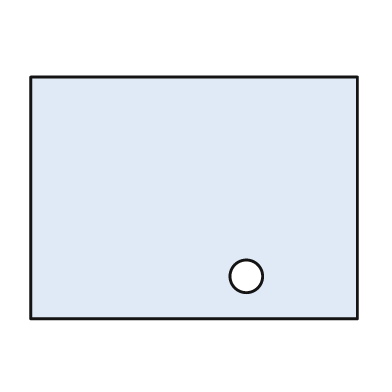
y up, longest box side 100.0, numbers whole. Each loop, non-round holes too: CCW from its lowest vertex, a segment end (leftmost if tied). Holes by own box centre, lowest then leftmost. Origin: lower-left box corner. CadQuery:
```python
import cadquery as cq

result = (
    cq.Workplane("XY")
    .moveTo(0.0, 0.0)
    .lineTo(100.0, 0.0)
    .lineTo(100.0, 74.0)
    .lineTo(0.0, 74.0)
    .close()
    .moveTo(66.0, 13.0)
    .circle(5.0)
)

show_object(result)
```